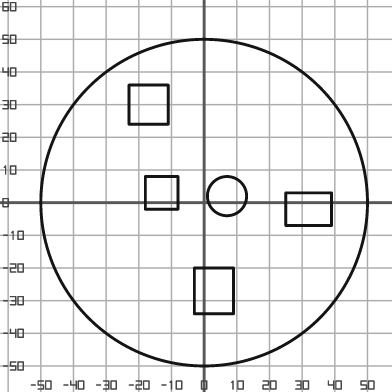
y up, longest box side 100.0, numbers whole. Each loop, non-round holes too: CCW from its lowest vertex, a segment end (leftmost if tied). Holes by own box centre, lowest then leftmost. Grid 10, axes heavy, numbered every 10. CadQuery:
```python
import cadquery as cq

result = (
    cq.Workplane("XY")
    .moveTo(0.0, 0.0)
    .circle(50.0)
    .moveTo(-3.0, -34.0)
    .lineTo(9.0, -34.0)
    .lineTo(9.0, -20.0)
    .lineTo(-3.0, -20.0)
    .close()
    .moveTo(25.0, -7.0)
    .lineTo(39.0, -7.0)
    .lineTo(39.0, 3.0)
    .lineTo(25.0, 3.0)
    .close()
    .moveTo(7.0, 2.0)
    .circle(6.0)
    .moveTo(-18.0, -2.0)
    .lineTo(-8.0, -2.0)
    .lineTo(-8.0, 8.0)
    .lineTo(-18.0, 8.0)
    .close()
    .moveTo(-23.0, 24.0)
    .lineTo(-11.0, 24.0)
    .lineTo(-11.0, 36.0)
    .lineTo(-23.0, 36.0)
    .close()
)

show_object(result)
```